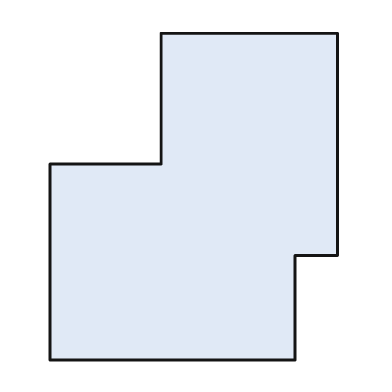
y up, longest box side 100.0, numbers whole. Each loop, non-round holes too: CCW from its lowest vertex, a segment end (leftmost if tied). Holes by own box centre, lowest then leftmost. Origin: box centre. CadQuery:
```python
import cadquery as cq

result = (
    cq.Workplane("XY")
    .moveTo(-44.0, -50.0)
    .lineTo(31.0, -50.0)
    .lineTo(31.0, -18.0)
    .lineTo(44.0, -18.0)
    .lineTo(44.0, 50.0)
    .lineTo(-10.0, 50.0)
    .lineTo(-10.0, 10.0)
    .lineTo(-44.0, 10.0)
    .close()
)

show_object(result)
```